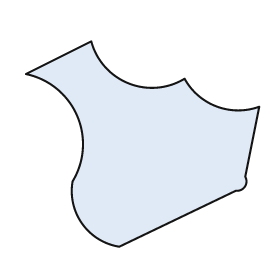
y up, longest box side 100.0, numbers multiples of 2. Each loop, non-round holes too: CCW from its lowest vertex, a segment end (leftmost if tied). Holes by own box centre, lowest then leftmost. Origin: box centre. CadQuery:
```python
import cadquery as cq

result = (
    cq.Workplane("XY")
    .moveTo(-10.0, -44.0)
    .lineTo(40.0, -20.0)
    .threePointArc((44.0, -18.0), (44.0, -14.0))
    .lineTo(50.0, 16.0)
    .threePointArc((32.0, 16.0), (18.0, 28.0))
    .threePointArc((-6.0, 26.0), (-22.0, 44.0))
    .lineTo(-50.0, 30.0)
    .threePointArc((-28.0, 12.0), (-30.0, -16.0))
    .threePointArc((-26.0, -34.0), (-10.0, -44.0))
    .close()
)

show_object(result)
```